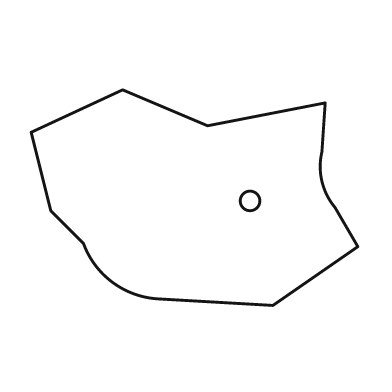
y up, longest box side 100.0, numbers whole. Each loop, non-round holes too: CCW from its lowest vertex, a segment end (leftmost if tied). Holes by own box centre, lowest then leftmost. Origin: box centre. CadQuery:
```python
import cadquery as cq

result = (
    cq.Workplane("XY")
    .moveTo(24.0, -33.0)
    .lineTo(50.0, -15.0)
    .lineTo(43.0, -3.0)
    .threePointArc((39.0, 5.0), (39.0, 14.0))
    .lineTo(40.0, 29.0)
    .lineTo(4.0, 22.0)
    .lineTo(-22.0, 33.0)
    .lineTo(-50.0, 20.0)
    .lineTo(-44.0, -4.0)
    .lineTo(-34.0, -14.0)
    .threePointArc((-25.0, -26.0), (-11.0, -31.0))
    .close()
    .moveTo(17.0, -1.0)
    .circle(3.0)
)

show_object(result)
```